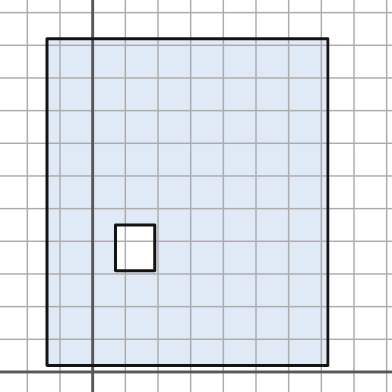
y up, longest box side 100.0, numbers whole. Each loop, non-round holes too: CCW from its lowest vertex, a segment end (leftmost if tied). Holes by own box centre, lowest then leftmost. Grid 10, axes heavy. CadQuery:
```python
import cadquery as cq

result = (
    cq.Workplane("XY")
    .moveTo(-14.0, 2.0)
    .lineTo(72.0, 2.0)
    .lineTo(72.0, 102.0)
    .lineTo(-14.0, 102.0)
    .close()
    .moveTo(7.0, 31.0)
    .lineTo(19.0, 31.0)
    .lineTo(19.0, 45.0)
    .lineTo(7.0, 45.0)
    .close()
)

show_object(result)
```